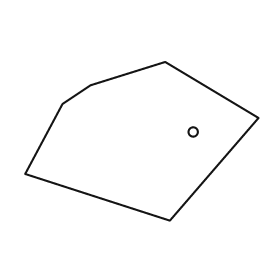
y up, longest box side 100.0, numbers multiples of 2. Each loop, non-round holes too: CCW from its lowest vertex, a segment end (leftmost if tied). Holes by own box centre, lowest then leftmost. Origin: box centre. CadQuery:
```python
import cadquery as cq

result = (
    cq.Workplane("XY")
    .moveTo(12.0, -34.0)
    .lineTo(50.0, 10.0)
    .lineTo(10.0, 34.0)
    .lineTo(-22.0, 24.0)
    .lineTo(-34.0, 16.0)
    .lineTo(-50.0, -14.0)
    .close()
    .moveTo(22.0, 4.0)
    .circle(2.0)
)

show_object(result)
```